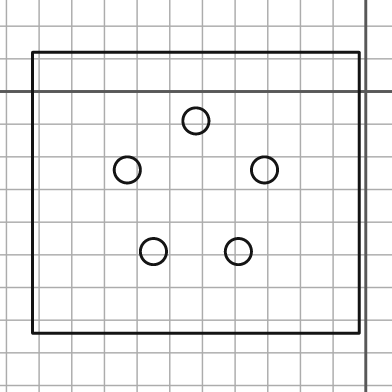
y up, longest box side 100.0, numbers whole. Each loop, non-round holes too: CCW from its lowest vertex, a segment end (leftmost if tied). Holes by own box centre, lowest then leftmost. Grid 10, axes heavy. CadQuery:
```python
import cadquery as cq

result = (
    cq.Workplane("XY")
    .moveTo(-102.0, -74.0)
    .lineTo(-2.0, -74.0)
    .lineTo(-2.0, 12.0)
    .lineTo(-102.0, 12.0)
    .close()
    .moveTo(-65.0, -49.0)
    .circle(4.0)
    .moveTo(-39.0, -49.0)
    .circle(4.0)
    .moveTo(-73.0, -24.0)
    .circle(4.0)
    .moveTo(-31.0, -24.0)
    .circle(4.0)
    .moveTo(-52.0, -9.0)
    .circle(4.0)
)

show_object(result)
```